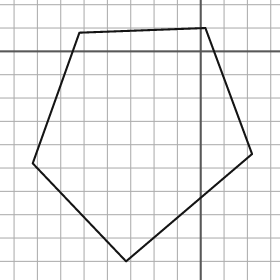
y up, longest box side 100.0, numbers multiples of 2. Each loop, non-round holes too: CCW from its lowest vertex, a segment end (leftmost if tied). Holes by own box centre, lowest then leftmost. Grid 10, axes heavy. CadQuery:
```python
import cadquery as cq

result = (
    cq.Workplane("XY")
    .moveTo(-32.0, -90.0)
    .lineTo(22.0, -44.0)
    .lineTo(2.0, 10.0)
    .lineTo(-52.0, 8.0)
    .lineTo(-72.0, -48.0)
    .close()
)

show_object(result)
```